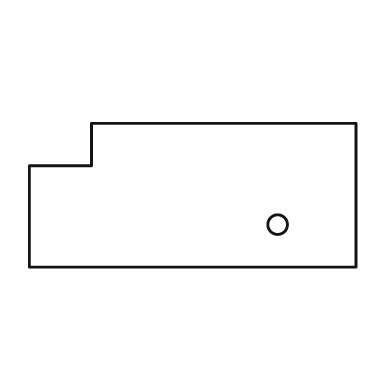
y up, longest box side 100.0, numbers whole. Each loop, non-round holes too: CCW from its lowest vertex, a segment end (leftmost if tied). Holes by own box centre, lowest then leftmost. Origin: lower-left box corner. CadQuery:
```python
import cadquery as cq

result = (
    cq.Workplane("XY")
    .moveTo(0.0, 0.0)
    .lineTo(100.0, 0.0)
    .lineTo(100.0, 44.0)
    .lineTo(19.0, 44.0)
    .lineTo(19.0, 31.0)
    .lineTo(0.0, 31.0)
    .close()
    .moveTo(76.0, 13.0)
    .circle(3.0)
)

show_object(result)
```